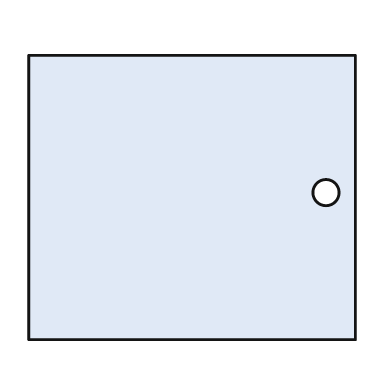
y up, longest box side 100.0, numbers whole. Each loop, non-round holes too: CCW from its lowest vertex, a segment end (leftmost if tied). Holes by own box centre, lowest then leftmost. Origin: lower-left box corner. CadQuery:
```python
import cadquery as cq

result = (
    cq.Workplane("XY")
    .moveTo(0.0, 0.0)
    .lineTo(100.0, 0.0)
    .lineTo(100.0, 87.0)
    .lineTo(0.0, 87.0)
    .close()
    .moveTo(91.0, 45.0)
    .circle(4.0)
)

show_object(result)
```